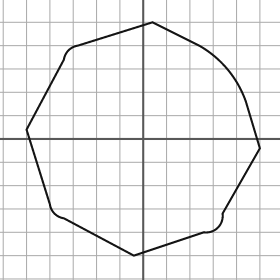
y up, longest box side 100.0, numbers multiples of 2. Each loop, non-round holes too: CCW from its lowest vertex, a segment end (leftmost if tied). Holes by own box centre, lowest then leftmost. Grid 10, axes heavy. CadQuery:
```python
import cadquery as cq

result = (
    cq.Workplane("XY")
    .moveTo(-4.0, -50.0)
    .lineTo(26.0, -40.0)
    .threePointArc((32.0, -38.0), (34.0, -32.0))
    .lineTo(50.0, -4.0)
    .lineTo(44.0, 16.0)
    .threePointArc((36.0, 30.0), (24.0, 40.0))
    .lineTo(4.0, 50.0)
    .lineTo(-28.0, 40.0)
    .threePointArc((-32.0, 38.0), (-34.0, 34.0))
    .lineTo(-50.0, 4.0)
    .lineTo(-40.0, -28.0)
    .threePointArc((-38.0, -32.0), (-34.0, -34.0))
    .close()
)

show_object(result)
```